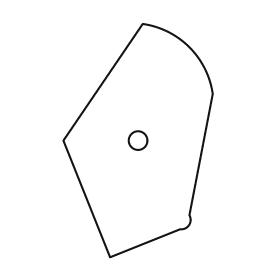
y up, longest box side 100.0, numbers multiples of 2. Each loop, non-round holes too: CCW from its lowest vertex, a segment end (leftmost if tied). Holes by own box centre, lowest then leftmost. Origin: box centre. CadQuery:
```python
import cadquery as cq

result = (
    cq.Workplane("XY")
    .moveTo(-12.0, -50.0)
    .lineTo(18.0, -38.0)
    .threePointArc((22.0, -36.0), (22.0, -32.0))
    .lineTo(32.0, 20.0)
    .threePointArc((22.0, 40.0), (2.0, 50.0))
    .lineTo(-32.0, 0.0)
    .close()
    .moveTo(0.0, 0.0)
    .circle(4.0)
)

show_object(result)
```